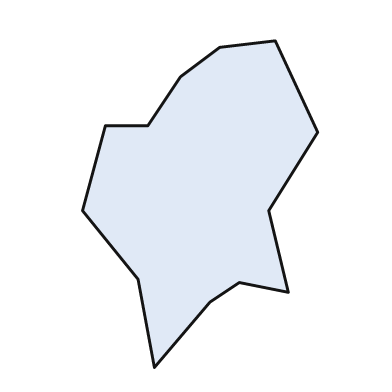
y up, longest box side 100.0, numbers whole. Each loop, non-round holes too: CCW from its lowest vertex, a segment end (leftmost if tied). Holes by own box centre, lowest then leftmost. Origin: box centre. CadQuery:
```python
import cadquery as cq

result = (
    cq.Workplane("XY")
    .moveTo(-14.0, -50.0)
    .lineTo(3.0, -30.0)
    .lineTo(12.0, -24.0)
    .lineTo(27.0, -27.0)
    .lineTo(21.0, -2.0)
    .lineTo(36.0, 22.0)
    .lineTo(23.0, 50.0)
    .lineTo(6.0, 48.0)
    .lineTo(-6.0, 39.0)
    .lineTo(-16.0, 24.0)
    .lineTo(-29.0, 24.0)
    .lineTo(-36.0, -2.0)
    .lineTo(-19.0, -23.0)
    .close()
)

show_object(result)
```